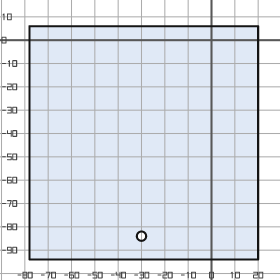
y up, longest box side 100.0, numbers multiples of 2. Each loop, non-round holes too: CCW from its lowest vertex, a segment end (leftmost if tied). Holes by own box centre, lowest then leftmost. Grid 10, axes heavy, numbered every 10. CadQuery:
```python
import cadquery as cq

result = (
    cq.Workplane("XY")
    .moveTo(-78.0, -94.0)
    .lineTo(20.0, -94.0)
    .lineTo(20.0, 6.0)
    .lineTo(-78.0, 6.0)
    .close()
    .moveTo(-30.0, -84.0)
    .circle(2.0)
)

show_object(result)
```